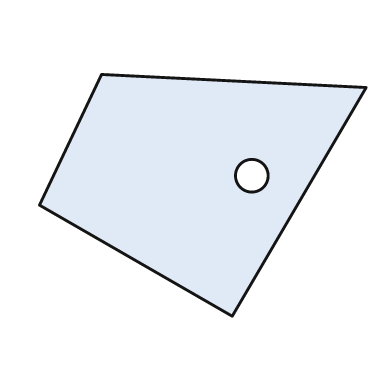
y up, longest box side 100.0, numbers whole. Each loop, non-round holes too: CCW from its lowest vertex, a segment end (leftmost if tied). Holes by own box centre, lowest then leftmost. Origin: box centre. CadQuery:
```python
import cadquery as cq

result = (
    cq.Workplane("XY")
    .moveTo(9.0, -37.0)
    .lineTo(50.0, 33.0)
    .lineTo(-31.0, 37.0)
    .lineTo(-50.0, -3.0)
    .close()
    .moveTo(15.0, 6.0)
    .circle(5.0)
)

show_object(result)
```